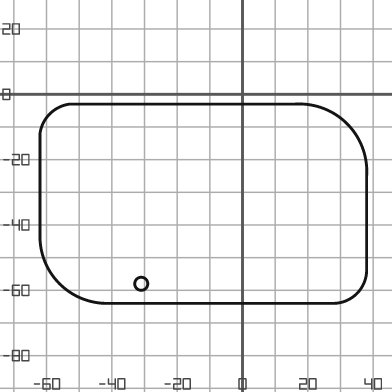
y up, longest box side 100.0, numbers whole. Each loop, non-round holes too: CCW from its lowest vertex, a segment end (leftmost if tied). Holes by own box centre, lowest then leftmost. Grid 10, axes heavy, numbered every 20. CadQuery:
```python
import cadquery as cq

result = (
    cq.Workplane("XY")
    .moveTo(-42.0, -64.0)
    .lineTo(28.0, -64.0)
    .threePointArc((35.0, -61.0), (38.0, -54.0))
    .lineTo(38.0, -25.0)
    .threePointArc((32.0, -9.0), (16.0, -3.0))
    .lineTo(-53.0, -3.0)
    .threePointArc((-59.0, -6.0), (-62.0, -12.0))
    .lineTo(-62.0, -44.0)
    .threePointArc((-56.0, -58.0), (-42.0, -64.0))
    .close()
    .moveTo(-31.0, -58.0)
    .circle(2.0)
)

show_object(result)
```